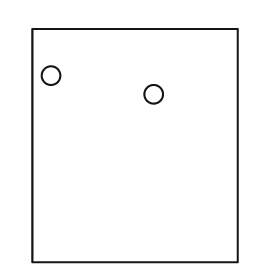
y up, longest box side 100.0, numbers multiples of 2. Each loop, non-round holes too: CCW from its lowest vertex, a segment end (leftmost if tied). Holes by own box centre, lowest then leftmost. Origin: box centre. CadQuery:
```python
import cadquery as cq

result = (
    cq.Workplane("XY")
    .moveTo(-44.0, -50.0)
    .lineTo(44.0, -50.0)
    .lineTo(44.0, 50.0)
    .lineTo(-44.0, 50.0)
    .close()
    .moveTo(8.0, 22.0)
    .circle(4.0)
    .moveTo(-36.0, 30.0)
    .circle(4.0)
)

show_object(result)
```